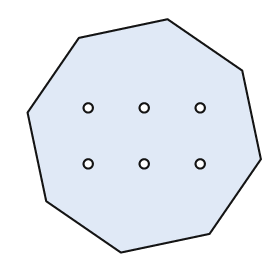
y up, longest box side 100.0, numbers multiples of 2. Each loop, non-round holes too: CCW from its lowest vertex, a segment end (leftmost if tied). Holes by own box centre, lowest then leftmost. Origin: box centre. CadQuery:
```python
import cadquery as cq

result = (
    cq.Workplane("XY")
    .moveTo(-10.0, -50.0)
    .lineTo(28.0, -42.0)
    .lineTo(50.0, -10.0)
    .lineTo(42.0, 28.0)
    .lineTo(10.0, 50.0)
    .lineTo(-28.0, 42.0)
    .lineTo(-50.0, 10.0)
    .lineTo(-42.0, -28.0)
    .close()
    .moveTo(-24.0, -12.0)
    .circle(2.0)
    .moveTo(0.0, -12.0)
    .circle(2.0)
    .moveTo(24.0, -12.0)
    .circle(2.0)
    .moveTo(-24.0, 12.0)
    .circle(2.0)
    .moveTo(0.0, 12.0)
    .circle(2.0)
    .moveTo(24.0, 12.0)
    .circle(2.0)
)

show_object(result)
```